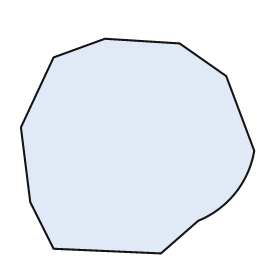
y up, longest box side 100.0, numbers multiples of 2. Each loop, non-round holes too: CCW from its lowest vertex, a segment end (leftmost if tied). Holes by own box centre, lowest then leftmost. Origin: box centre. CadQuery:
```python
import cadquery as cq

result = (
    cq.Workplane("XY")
    .moveTo(10.0, -46.0)
    .lineTo(26.0, -32.0)
    .threePointArc((42.0, -20.0), (50.0, -2.0))
    .lineTo(38.0, 30.0)
    .lineTo(18.0, 44.0)
    .lineTo(-14.0, 46.0)
    .lineTo(-36.0, 38.0)
    .lineTo(-50.0, 8.0)
    .lineTo(-46.0, -24.0)
    .lineTo(-36.0, -44.0)
    .close()
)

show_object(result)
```